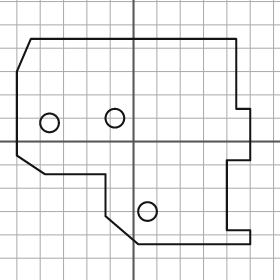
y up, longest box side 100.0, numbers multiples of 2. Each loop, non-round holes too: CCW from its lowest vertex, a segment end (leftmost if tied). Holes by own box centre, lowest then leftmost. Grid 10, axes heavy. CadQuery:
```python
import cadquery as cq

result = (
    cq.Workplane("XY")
    .moveTo(2.0, -44.0)
    .lineTo(50.0, -44.0)
    .lineTo(50.0, -38.0)
    .lineTo(40.0, -38.0)
    .lineTo(40.0, -8.0)
    .lineTo(50.0, -8.0)
    .lineTo(50.0, 14.0)
    .lineTo(44.0, 14.0)
    .lineTo(44.0, 44.0)
    .lineTo(-44.0, 44.0)
    .lineTo(-50.0, 30.0)
    .lineTo(-50.0, -6.0)
    .lineTo(-38.0, -14.0)
    .lineTo(-12.0, -14.0)
    .lineTo(-12.0, -32.0)
    .close()
    .moveTo(6.0, -30.0)
    .circle(4.0)
    .moveTo(-36.0, 8.0)
    .circle(4.0)
    .moveTo(-8.0, 10.0)
    .circle(4.0)
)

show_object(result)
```